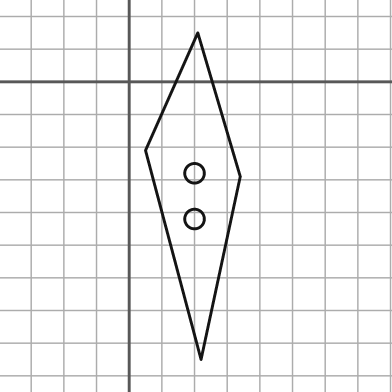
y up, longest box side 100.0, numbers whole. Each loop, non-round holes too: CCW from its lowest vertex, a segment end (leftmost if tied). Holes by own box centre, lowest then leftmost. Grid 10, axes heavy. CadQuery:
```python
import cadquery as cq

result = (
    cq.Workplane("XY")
    .moveTo(22.0, -85.0)
    .lineTo(34.0, -29.0)
    .lineTo(21.0, 15.0)
    .lineTo(5.0, -21.0)
    .close()
    .moveTo(20.0, -42.0)
    .circle(3.0)
    .moveTo(20.0, -28.0)
    .circle(3.0)
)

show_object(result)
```